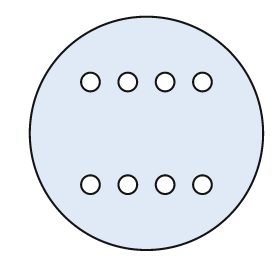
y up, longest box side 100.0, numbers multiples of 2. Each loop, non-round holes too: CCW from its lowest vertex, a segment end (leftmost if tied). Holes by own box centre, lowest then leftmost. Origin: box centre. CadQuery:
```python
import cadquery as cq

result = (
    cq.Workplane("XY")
    .moveTo(0.0, 0.0)
    .circle(50.0)
    .moveTo(-24.0, -22.0)
    .circle(4.0)
    .moveTo(-8.0, -22.0)
    .circle(4.0)
    .moveTo(8.0, -22.0)
    .circle(4.0)
    .moveTo(24.0, -22.0)
    .circle(4.0)
    .moveTo(-24.0, 22.0)
    .circle(4.0)
    .moveTo(-8.0, 22.0)
    .circle(4.0)
    .moveTo(8.0, 22.0)
    .circle(4.0)
    .moveTo(24.0, 22.0)
    .circle(4.0)
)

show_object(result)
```